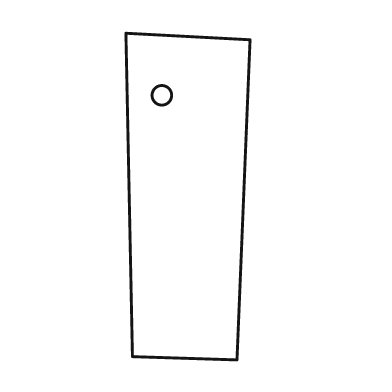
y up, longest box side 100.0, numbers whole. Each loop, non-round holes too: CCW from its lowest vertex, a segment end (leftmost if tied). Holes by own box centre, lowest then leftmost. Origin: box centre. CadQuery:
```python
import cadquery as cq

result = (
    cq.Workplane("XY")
    .moveTo(15.0, -50.0)
    .lineTo(19.0, 48.0)
    .lineTo(-19.0, 50.0)
    .lineTo(-17.0, -49.0)
    .close()
    .moveTo(-8.0, 31.0)
    .circle(3.0)
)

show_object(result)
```